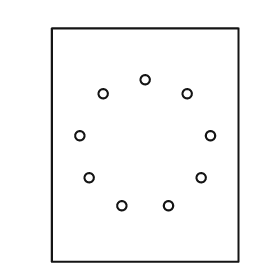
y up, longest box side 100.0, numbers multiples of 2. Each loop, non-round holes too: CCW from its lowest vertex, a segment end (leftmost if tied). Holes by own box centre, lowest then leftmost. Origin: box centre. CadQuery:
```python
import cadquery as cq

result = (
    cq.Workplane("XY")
    .moveTo(-40.0, -50.0)
    .lineTo(40.0, -50.0)
    .lineTo(40.0, 50.0)
    .lineTo(-40.0, 50.0)
    .close()
    .moveTo(-10.0, -26.0)
    .circle(2.0)
    .moveTo(10.0, -26.0)
    .circle(2.0)
    .moveTo(-24.0, -14.0)
    .circle(2.0)
    .moveTo(24.0, -14.0)
    .circle(2.0)
    .moveTo(-28.0, 4.0)
    .circle(2.0)
    .moveTo(28.0, 4.0)
    .circle(2.0)
    .moveTo(-18.0, 22.0)
    .circle(2.0)
    .moveTo(18.0, 22.0)
    .circle(2.0)
    .moveTo(0.0, 28.0)
    .circle(2.0)
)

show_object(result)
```